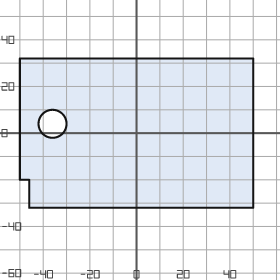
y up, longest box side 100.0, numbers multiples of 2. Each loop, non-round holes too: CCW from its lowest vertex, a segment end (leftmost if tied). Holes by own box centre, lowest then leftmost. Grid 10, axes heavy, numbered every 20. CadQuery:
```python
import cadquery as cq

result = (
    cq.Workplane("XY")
    .moveTo(-46.0, -32.0)
    .lineTo(50.0, -32.0)
    .lineTo(50.0, 32.0)
    .lineTo(-50.0, 32.0)
    .lineTo(-50.0, -20.0)
    .lineTo(-46.0, -20.0)
    .close()
    .moveTo(-36.0, 4.0)
    .circle(6.0)
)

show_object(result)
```